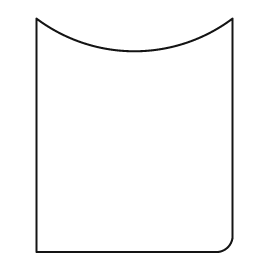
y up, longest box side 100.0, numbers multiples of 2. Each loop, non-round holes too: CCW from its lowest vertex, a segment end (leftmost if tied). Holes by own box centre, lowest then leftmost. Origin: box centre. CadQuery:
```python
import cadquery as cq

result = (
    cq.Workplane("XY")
    .moveTo(-42.0, -50.0)
    .lineTo(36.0, -50.0)
    .threePointArc((40.0, -48.0), (42.0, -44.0))
    .lineTo(42.0, 50.0)
    .threePointArc((0.0, 36.0), (-42.0, 50.0))
    .close()
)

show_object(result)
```